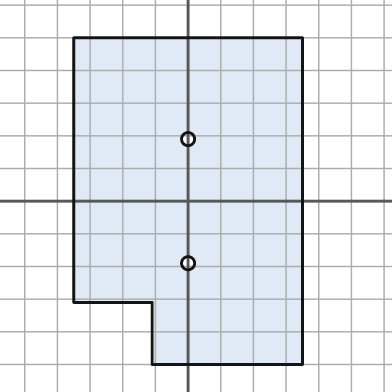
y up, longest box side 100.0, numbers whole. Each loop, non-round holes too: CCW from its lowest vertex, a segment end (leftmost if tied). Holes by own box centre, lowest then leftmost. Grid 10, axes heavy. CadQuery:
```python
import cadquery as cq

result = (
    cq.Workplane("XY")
    .moveTo(-11.0, -50.0)
    .lineTo(35.0, -50.0)
    .lineTo(35.0, 50.0)
    .lineTo(-35.0, 50.0)
    .lineTo(-35.0, -31.0)
    .lineTo(-11.0, -31.0)
    .close()
    .moveTo(0.0, -19.0)
    .circle(2.0)
    .moveTo(0.0, 19.0)
    .circle(2.0)
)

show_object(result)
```